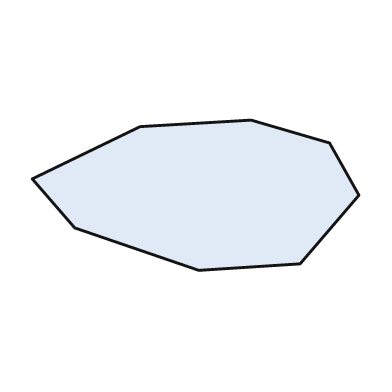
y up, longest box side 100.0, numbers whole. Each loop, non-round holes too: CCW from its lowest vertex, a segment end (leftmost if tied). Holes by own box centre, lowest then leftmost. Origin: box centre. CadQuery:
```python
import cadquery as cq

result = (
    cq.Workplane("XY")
    .moveTo(1.0, -23.0)
    .lineTo(32.0, -21.0)
    .lineTo(50.0, 0.0)
    .lineTo(41.0, 16.0)
    .lineTo(17.0, 23.0)
    .lineTo(-17.0, 21.0)
    .lineTo(-50.0, 5.0)
    .lineTo(-37.0, -10.0)
    .close()
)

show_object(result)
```